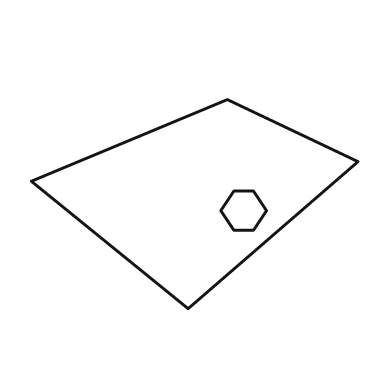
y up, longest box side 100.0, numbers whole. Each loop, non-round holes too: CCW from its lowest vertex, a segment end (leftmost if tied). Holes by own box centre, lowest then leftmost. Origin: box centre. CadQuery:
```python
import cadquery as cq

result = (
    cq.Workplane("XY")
    .moveTo(-2.0, -32.0)
    .lineTo(50.0, 13.0)
    .lineTo(10.0, 32.0)
    .lineTo(-50.0, 7.0)
    .close()
    .moveTo(12.0, -8.0)
    .lineTo(18.0, -8.0)
    .lineTo(22.0, -2.0)
    .lineTo(18.0, 4.0)
    .lineTo(12.0, 4.0)
    .lineTo(8.0, -2.0)
    .close()
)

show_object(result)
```